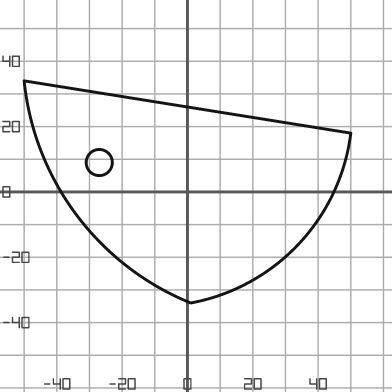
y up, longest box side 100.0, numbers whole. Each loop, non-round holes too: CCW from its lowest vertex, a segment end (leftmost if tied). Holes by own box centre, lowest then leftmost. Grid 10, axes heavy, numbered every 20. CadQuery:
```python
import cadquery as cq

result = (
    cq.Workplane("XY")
    .moveTo(1.0, -34.0)
    .threePointArc((34.0, -16.0), (50.0, 18.0))
    .lineTo(-50.0, 34.0)
    .threePointArc((-34.0, -7.0), (1.0, -34.0))
    .close()
    .moveTo(-27.0, 9.0)
    .circle(4.0)
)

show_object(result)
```